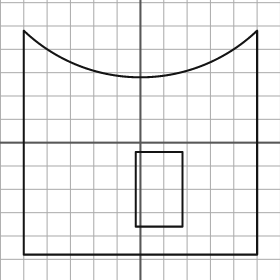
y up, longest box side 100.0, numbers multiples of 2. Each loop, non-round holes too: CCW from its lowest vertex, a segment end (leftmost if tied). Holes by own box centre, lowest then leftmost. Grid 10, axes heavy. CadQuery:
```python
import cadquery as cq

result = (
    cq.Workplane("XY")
    .moveTo(-50.0, -48.0)
    .lineTo(50.0, -48.0)
    .lineTo(50.0, 48.0)
    .threePointArc((0.0, 28.0), (-50.0, 48.0))
    .close()
    .moveTo(-2.0, -36.0)
    .lineTo(18.0, -36.0)
    .lineTo(18.0, -4.0)
    .lineTo(-2.0, -4.0)
    .close()
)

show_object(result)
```